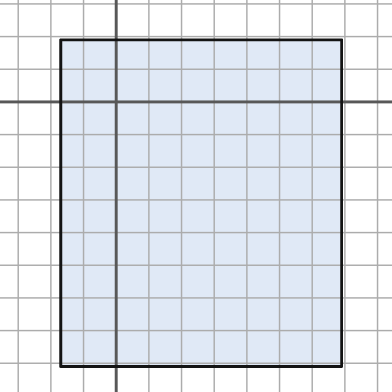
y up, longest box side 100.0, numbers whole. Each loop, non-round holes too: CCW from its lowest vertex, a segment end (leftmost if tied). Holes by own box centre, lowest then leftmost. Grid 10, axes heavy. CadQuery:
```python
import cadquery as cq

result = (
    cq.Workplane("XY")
    .moveTo(-17.0, -81.0)
    .lineTo(69.0, -81.0)
    .lineTo(69.0, 19.0)
    .lineTo(-17.0, 19.0)
    .close()
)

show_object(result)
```